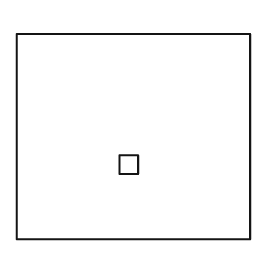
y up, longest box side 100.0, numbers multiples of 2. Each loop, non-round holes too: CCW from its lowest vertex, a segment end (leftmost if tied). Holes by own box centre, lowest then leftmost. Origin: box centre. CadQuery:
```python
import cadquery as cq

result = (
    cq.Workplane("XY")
    .moveTo(-50.0, -44.0)
    .lineTo(50.0, -44.0)
    .lineTo(50.0, 44.0)
    .lineTo(-50.0, 44.0)
    .close()
    .moveTo(-6.0, -16.0)
    .lineTo(2.0, -16.0)
    .lineTo(2.0, -8.0)
    .lineTo(-6.0, -8.0)
    .close()
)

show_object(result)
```